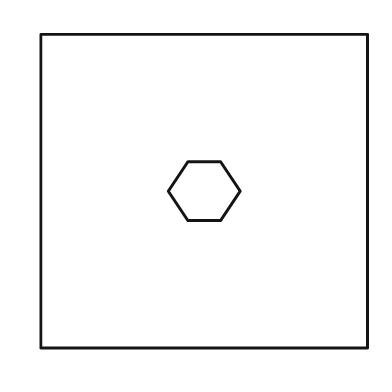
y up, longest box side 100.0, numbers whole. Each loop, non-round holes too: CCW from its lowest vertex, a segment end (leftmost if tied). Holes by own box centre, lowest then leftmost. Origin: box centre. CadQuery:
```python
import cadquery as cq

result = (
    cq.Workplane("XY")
    .moveTo(-50.0, -48.0)
    .lineTo(50.0, -48.0)
    .lineTo(50.0, 48.0)
    .lineTo(-50.0, 48.0)
    .close()
    .moveTo(-5.0, -9.0)
    .lineTo(5.0, -9.0)
    .lineTo(11.0, 0.0)
    .lineTo(5.0, 9.0)
    .lineTo(-5.0, 9.0)
    .lineTo(-11.0, 0.0)
    .close()
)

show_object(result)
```